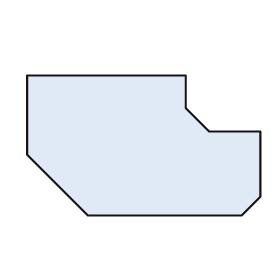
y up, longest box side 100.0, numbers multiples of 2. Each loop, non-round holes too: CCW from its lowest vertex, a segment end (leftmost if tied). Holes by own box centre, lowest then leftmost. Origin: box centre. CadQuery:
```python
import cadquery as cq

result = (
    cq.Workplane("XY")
    .moveTo(-24.0, -30.0)
    .lineTo(42.0, -30.0)
    .lineTo(50.0, -22.0)
    .lineTo(50.0, 6.0)
    .lineTo(28.0, 6.0)
    .lineTo(18.0, 16.0)
    .lineTo(18.0, 30.0)
    .lineTo(-50.0, 30.0)
    .lineTo(-50.0, -4.0)
    .close()
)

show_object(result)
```